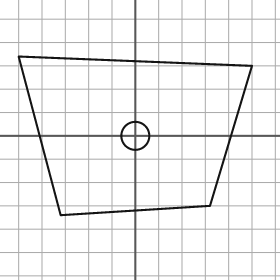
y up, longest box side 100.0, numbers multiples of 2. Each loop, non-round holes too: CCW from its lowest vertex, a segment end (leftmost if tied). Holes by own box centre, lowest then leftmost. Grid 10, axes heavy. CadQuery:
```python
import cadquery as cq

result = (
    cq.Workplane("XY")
    .moveTo(-32.0, -34.0)
    .lineTo(32.0, -30.0)
    .lineTo(50.0, 30.0)
    .lineTo(-50.0, 34.0)
    .close()
    .moveTo(0.0, 0.0)
    .circle(6.0)
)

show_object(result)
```